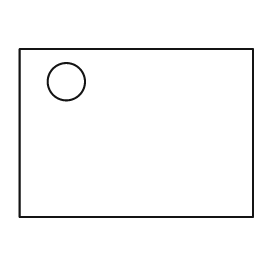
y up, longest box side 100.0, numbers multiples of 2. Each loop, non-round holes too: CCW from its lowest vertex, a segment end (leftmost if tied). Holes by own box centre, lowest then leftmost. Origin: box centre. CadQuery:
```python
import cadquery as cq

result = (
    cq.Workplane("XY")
    .moveTo(-50.0, -36.0)
    .lineTo(50.0, -36.0)
    .lineTo(50.0, 36.0)
    .lineTo(-50.0, 36.0)
    .close()
    .moveTo(-30.0, 22.0)
    .circle(8.0)
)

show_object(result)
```